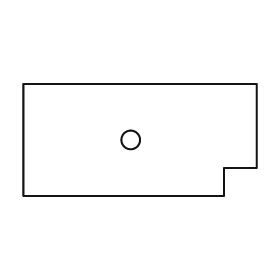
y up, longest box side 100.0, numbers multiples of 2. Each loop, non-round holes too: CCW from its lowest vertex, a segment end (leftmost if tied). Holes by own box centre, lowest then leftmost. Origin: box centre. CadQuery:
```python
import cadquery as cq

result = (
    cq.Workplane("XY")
    .moveTo(-50.0, -24.0)
    .lineTo(36.0, -24.0)
    .lineTo(36.0, -12.0)
    .lineTo(50.0, -12.0)
    .lineTo(50.0, 24.0)
    .lineTo(-50.0, 24.0)
    .close()
    .moveTo(-4.0, 0.0)
    .circle(4.0)
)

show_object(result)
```